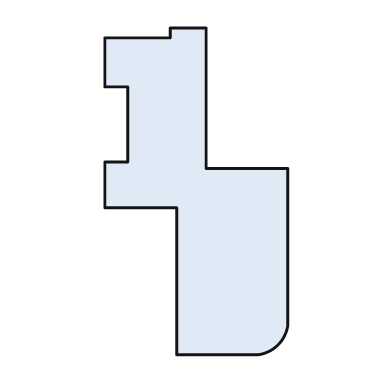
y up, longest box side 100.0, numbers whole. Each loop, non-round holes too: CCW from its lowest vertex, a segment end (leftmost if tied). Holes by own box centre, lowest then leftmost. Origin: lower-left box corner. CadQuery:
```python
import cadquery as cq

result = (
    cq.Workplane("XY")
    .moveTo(22.0, 0.0)
    .lineTo(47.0, 0.0)
    .threePointArc((53.0, 3.0), (56.0, 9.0))
    .lineTo(56.0, 57.0)
    .lineTo(31.0, 57.0)
    .lineTo(31.0, 100.0)
    .lineTo(20.0, 100.0)
    .lineTo(20.0, 97.0)
    .lineTo(0.0, 97.0)
    .lineTo(0.0, 82.0)
    .lineTo(7.0, 82.0)
    .lineTo(7.0, 59.0)
    .lineTo(0.0, 59.0)
    .lineTo(0.0, 45.0)
    .lineTo(22.0, 45.0)
    .close()
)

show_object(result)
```